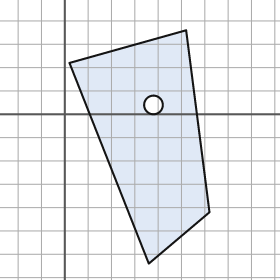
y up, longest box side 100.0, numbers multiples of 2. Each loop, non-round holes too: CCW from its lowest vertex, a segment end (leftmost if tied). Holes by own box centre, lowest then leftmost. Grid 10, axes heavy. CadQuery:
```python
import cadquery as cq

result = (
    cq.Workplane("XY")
    .moveTo(36.0, -64.0)
    .lineTo(62.0, -42.0)
    .lineTo(52.0, 36.0)
    .lineTo(2.0, 22.0)
    .close()
    .moveTo(38.0, 4.0)
    .circle(4.0)
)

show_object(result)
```